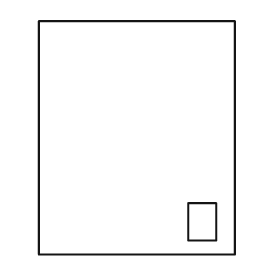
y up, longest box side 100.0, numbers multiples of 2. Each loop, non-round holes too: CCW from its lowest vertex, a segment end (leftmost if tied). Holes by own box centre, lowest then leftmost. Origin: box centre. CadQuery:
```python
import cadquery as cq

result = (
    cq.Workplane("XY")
    .moveTo(-42.0, -50.0)
    .lineTo(42.0, -50.0)
    .lineTo(42.0, 50.0)
    .lineTo(-42.0, 50.0)
    .close()
    .moveTo(22.0, -44.0)
    .lineTo(34.0, -44.0)
    .lineTo(34.0, -28.0)
    .lineTo(22.0, -28.0)
    .close()
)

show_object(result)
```